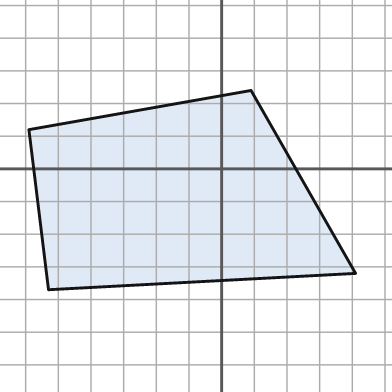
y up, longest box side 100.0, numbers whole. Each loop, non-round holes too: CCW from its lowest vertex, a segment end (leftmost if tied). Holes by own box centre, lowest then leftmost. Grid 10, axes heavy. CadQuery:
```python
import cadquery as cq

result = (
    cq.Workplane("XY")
    .moveTo(-53.0, -37.0)
    .lineTo(41.0, -32.0)
    .lineTo(9.0, 24.0)
    .lineTo(-59.0, 12.0)
    .close()
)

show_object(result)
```